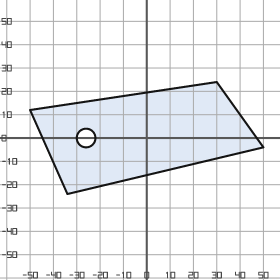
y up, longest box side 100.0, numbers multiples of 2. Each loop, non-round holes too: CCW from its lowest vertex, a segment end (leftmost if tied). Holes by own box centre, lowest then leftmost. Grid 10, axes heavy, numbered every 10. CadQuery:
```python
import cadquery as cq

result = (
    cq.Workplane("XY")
    .moveTo(-34.0, -24.0)
    .lineTo(50.0, -4.0)
    .lineTo(30.0, 24.0)
    .lineTo(-50.0, 12.0)
    .close()
    .moveTo(-26.0, 0.0)
    .circle(4.0)
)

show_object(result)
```